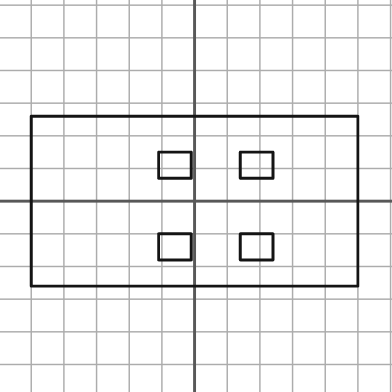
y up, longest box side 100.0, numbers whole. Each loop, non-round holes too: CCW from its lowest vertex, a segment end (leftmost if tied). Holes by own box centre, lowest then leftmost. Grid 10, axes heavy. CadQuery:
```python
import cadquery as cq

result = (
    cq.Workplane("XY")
    .moveTo(-50.0, -26.0)
    .lineTo(50.0, -26.0)
    .lineTo(50.0, 26.0)
    .lineTo(-50.0, 26.0)
    .close()
    .moveTo(-11.0, -18.0)
    .lineTo(-1.0, -18.0)
    .lineTo(-1.0, -10.0)
    .lineTo(-11.0, -10.0)
    .close()
    .moveTo(14.0, -18.0)
    .lineTo(24.0, -18.0)
    .lineTo(24.0, -10.0)
    .lineTo(14.0, -10.0)
    .close()
    .moveTo(-11.0, 7.0)
    .lineTo(-1.0, 7.0)
    .lineTo(-1.0, 15.0)
    .lineTo(-11.0, 15.0)
    .close()
    .moveTo(14.0, 7.0)
    .lineTo(24.0, 7.0)
    .lineTo(24.0, 15.0)
    .lineTo(14.0, 15.0)
    .close()
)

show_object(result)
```